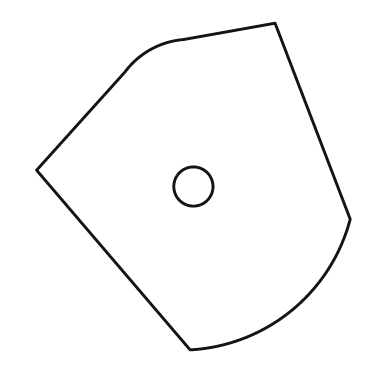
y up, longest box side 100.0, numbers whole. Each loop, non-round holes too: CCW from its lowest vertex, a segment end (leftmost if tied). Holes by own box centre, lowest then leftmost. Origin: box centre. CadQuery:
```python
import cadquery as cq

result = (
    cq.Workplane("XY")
    .moveTo(-1.0, -50.0)
    .threePointArc((30.0, -38.0), (48.0, -10.0))
    .lineTo(25.0, 50.0)
    .lineTo(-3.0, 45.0)
    .threePointArc((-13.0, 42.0), (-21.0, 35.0))
    .lineTo(-48.0, 5.0)
    .close()
    .moveTo(0.0, 0.0)
    .circle(6.0)
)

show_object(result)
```